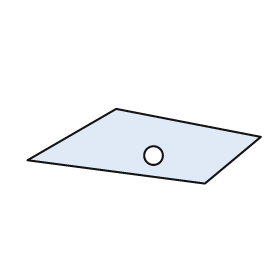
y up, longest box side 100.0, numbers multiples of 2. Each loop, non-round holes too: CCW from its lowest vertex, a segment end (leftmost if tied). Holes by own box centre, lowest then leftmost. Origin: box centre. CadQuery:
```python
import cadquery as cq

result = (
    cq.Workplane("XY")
    .moveTo(26.0, -16.0)
    .lineTo(50.0, 4.0)
    .lineTo(-12.0, 16.0)
    .lineTo(-50.0, -6.0)
    .close()
    .moveTo(4.0, -4.0)
    .circle(4.0)
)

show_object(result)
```